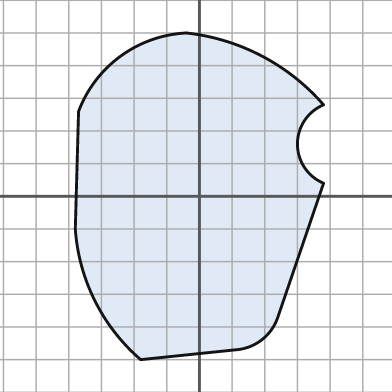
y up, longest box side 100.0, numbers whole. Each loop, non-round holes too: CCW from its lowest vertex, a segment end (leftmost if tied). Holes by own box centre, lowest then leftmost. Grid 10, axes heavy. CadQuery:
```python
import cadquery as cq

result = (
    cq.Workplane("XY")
    .moveTo(-18.0, -50.0)
    .lineTo(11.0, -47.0)
    .threePointArc((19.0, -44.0), (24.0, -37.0))
    .lineTo(38.0, 4.0)
    .threePointArc((30.0, 16.0), (38.0, 28.0))
    .threePointArc((19.0, 43.0), (-4.0, 50.0))
    .threePointArc((-24.0, 43.0), (-37.0, 26.0))
    .lineTo(-38.0, -10.0)
    .threePointArc((-32.0, -32.0), (-18.0, -50.0))
    .close()
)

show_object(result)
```